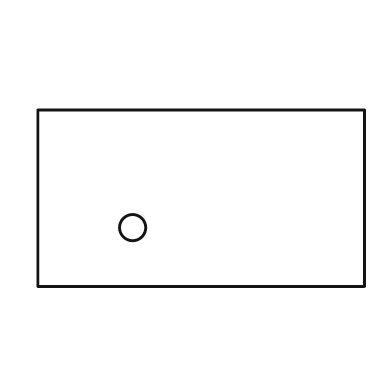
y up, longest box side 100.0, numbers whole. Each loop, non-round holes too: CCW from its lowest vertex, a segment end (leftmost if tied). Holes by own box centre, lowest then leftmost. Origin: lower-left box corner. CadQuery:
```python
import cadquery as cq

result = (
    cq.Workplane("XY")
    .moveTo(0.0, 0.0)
    .lineTo(100.0, 0.0)
    .lineTo(100.0, 54.0)
    .lineTo(0.0, 54.0)
    .close()
    .moveTo(29.0, 18.0)
    .circle(4.0)
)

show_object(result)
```